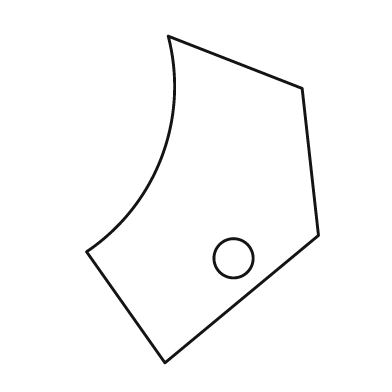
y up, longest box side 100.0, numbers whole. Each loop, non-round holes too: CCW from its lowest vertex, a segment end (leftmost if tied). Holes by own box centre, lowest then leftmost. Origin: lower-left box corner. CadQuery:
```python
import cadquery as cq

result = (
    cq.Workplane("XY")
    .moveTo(24.0, 0.0)
    .lineTo(71.0, 39.0)
    .lineTo(66.0, 84.0)
    .lineTo(25.0, 100.0)
    .threePointArc((23.0, 63.0), (0.0, 34.0))
    .close()
    .moveTo(45.0, 32.0)
    .circle(6.0)
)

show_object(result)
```